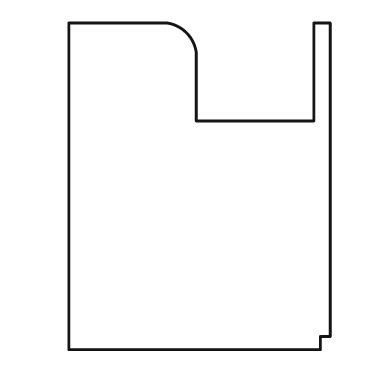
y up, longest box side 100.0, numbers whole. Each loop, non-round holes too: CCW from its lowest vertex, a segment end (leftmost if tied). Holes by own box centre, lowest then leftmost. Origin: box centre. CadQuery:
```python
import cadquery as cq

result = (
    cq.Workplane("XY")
    .moveTo(-40.0, -50.0)
    .lineTo(37.0, -50.0)
    .lineTo(37.0, -46.0)
    .lineTo(40.0, -46.0)
    .lineTo(40.0, 50.0)
    .lineTo(35.0, 50.0)
    .lineTo(35.0, 20.0)
    .lineTo(-1.0, 20.0)
    .lineTo(-1.0, 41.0)
    .threePointArc((-4.0, 47.0), (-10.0, 50.0))
    .lineTo(-40.0, 50.0)
    .close()
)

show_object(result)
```